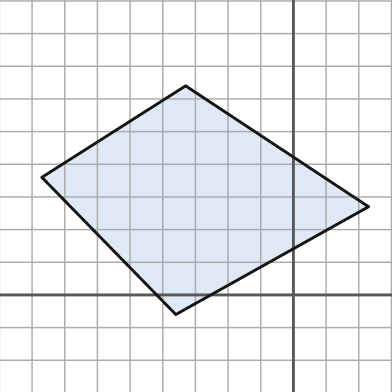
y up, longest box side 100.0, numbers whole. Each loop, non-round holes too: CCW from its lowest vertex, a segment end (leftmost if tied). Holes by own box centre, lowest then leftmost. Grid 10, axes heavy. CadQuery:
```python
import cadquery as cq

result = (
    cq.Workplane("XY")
    .moveTo(-36.0, -6.0)
    .lineTo(23.0, 27.0)
    .lineTo(-33.0, 64.0)
    .lineTo(-77.0, 36.0)
    .close()
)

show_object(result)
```